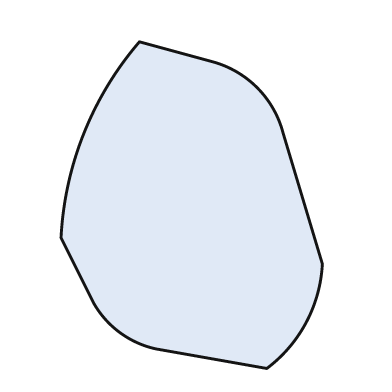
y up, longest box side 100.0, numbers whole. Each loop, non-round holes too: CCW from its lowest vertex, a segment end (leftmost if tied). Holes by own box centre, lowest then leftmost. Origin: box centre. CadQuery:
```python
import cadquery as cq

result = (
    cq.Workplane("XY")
    .moveTo(23.0, -50.0)
    .threePointArc((35.0, -36.0), (40.0, -18.0))
    .lineTo(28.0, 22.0)
    .threePointArc((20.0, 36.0), (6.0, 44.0))
    .lineTo(-16.0, 50.0)
    .threePointArc((-33.0, 22.0), (-40.0, -10.0))
    .lineTo(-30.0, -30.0)
    .threePointArc((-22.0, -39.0), (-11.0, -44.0))
    .close()
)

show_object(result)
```